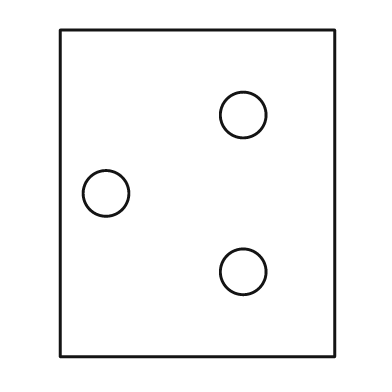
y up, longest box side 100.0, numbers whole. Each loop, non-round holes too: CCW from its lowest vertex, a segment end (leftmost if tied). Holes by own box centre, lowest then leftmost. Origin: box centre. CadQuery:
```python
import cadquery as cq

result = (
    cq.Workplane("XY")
    .moveTo(-42.0, -50.0)
    .lineTo(42.0, -50.0)
    .lineTo(42.0, 50.0)
    .lineTo(-42.0, 50.0)
    .close()
    .moveTo(14.0, -24.0)
    .circle(7.0)
    .moveTo(-28.0, 0.0)
    .circle(7.0)
    .moveTo(14.0, 24.0)
    .circle(7.0)
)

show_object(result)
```